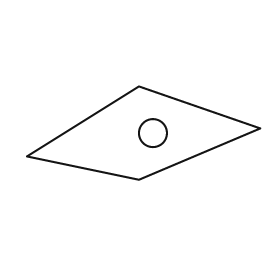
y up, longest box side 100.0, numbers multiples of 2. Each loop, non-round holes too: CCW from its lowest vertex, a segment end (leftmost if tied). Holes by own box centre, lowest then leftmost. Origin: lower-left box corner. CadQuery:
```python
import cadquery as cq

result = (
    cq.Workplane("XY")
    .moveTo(48.0, 0.0)
    .lineTo(100.0, 22.0)
    .lineTo(48.0, 40.0)
    .lineTo(0.0, 10.0)
    .close()
    .moveTo(54.0, 20.0)
    .circle(6.0)
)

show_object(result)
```